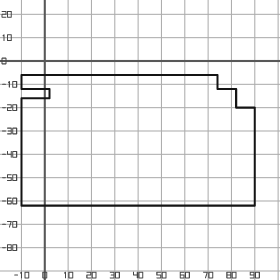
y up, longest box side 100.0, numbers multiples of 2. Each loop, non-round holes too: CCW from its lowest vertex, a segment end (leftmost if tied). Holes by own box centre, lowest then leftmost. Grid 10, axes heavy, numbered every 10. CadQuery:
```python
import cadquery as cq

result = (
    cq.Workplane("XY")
    .moveTo(-10.0, -62.0)
    .lineTo(90.0, -62.0)
    .lineTo(90.0, -20.0)
    .lineTo(82.0, -20.0)
    .lineTo(82.0, -12.0)
    .lineTo(74.0, -12.0)
    .lineTo(74.0, -6.0)
    .lineTo(-10.0, -6.0)
    .lineTo(-10.0, -12.0)
    .lineTo(2.0, -12.0)
    .lineTo(2.0, -16.0)
    .lineTo(-10.0, -16.0)
    .close()
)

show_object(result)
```